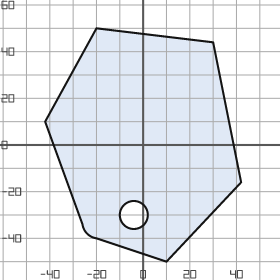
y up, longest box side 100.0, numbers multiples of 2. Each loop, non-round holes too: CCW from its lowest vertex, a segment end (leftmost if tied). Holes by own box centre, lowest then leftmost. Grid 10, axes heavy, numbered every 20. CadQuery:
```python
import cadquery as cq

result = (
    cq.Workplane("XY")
    .moveTo(10.0, -50.0)
    .lineTo(42.0, -16.0)
    .lineTo(30.0, 44.0)
    .lineTo(-20.0, 50.0)
    .lineTo(-42.0, 10.0)
    .lineTo(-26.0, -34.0)
    .threePointArc((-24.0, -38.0), (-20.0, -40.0))
    .close()
    .moveTo(-4.0, -30.0)
    .circle(6.0)
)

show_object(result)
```